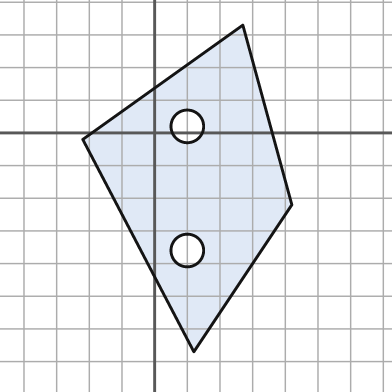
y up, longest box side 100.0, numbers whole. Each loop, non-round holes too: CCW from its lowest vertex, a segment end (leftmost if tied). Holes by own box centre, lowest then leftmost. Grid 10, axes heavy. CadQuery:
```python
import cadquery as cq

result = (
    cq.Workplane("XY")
    .moveTo(12.0, -67.0)
    .lineTo(42.0, -22.0)
    .lineTo(27.0, 33.0)
    .lineTo(-22.0, -2.0)
    .close()
    .moveTo(10.0, -36.0)
    .circle(5.0)
    .moveTo(10.0, 2.0)
    .circle(5.0)
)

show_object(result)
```